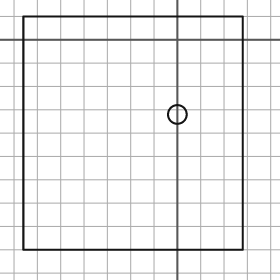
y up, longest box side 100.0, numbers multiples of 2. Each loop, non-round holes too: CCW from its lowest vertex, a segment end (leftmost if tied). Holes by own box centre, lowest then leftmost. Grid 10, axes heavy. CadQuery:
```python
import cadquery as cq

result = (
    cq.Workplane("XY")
    .moveTo(-66.0, -90.0)
    .lineTo(28.0, -90.0)
    .lineTo(28.0, 10.0)
    .lineTo(-66.0, 10.0)
    .close()
    .moveTo(0.0, -32.0)
    .circle(4.0)
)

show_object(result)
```